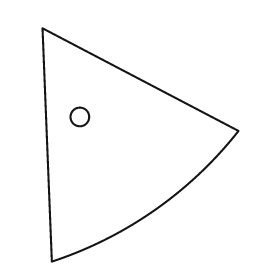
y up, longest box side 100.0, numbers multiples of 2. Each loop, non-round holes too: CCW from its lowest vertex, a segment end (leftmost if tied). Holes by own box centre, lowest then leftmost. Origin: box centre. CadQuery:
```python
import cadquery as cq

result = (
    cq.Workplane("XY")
    .moveTo(-38.0, -50.0)
    .threePointArc((6.0, -28.0), (42.0, 6.0))
    .lineTo(-42.0, 50.0)
    .close()
    .moveTo(-26.0, 12.0)
    .circle(4.0)
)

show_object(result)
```